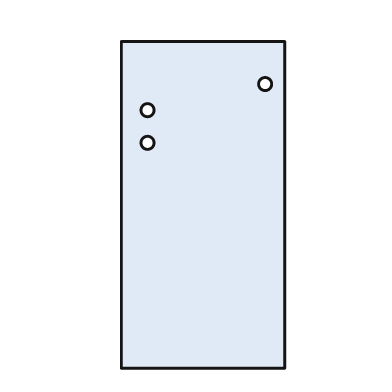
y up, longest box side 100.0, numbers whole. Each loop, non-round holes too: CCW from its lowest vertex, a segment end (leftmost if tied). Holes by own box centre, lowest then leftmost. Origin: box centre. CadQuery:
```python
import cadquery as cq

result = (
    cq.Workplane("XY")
    .moveTo(-25.0, -50.0)
    .lineTo(25.0, -50.0)
    .lineTo(25.0, 50.0)
    .lineTo(-25.0, 50.0)
    .close()
    .moveTo(-17.0, 19.0)
    .circle(2.0)
    .moveTo(-17.0, 29.0)
    .circle(2.0)
    .moveTo(19.0, 37.0)
    .circle(2.0)
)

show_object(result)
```